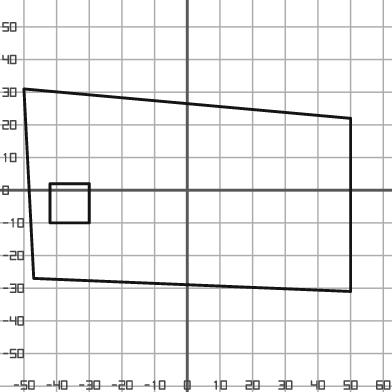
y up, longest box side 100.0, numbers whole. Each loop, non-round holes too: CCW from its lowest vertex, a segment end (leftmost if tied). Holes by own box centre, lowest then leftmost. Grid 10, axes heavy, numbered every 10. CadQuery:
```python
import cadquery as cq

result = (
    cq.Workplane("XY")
    .moveTo(50.0, -31.0)
    .lineTo(50.0, 22.0)
    .lineTo(-50.0, 31.0)
    .lineTo(-47.0, -27.0)
    .close()
    .moveTo(-42.0, -10.0)
    .lineTo(-30.0, -10.0)
    .lineTo(-30.0, 2.0)
    .lineTo(-42.0, 2.0)
    .close()
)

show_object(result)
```